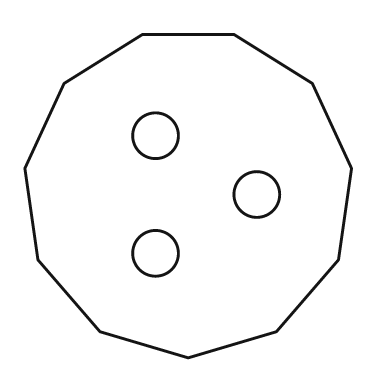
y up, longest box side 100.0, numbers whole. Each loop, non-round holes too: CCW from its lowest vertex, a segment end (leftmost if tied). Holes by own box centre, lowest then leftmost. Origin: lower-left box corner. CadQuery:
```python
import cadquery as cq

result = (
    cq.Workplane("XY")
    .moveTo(50.0, 0.0)
    .lineTo(77.0, 8.0)
    .lineTo(96.0, 30.0)
    .lineTo(100.0, 58.0)
    .lineTo(88.0, 84.0)
    .lineTo(64.0, 99.0)
    .lineTo(36.0, 99.0)
    .lineTo(12.0, 84.0)
    .lineTo(0.0, 58.0)
    .lineTo(4.0, 30.0)
    .lineTo(23.0, 8.0)
    .close()
    .moveTo(40.0, 32.0)
    .circle(7.0)
    .moveTo(71.0, 50.0)
    .circle(7.0)
    .moveTo(40.0, 68.0)
    .circle(7.0)
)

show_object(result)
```